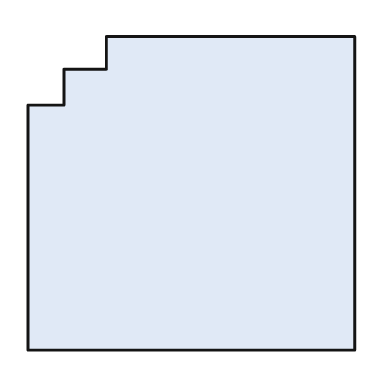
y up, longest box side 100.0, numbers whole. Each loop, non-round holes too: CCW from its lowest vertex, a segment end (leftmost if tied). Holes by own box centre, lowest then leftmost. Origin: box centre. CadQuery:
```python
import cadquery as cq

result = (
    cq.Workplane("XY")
    .moveTo(-50.0, -48.0)
    .lineTo(50.0, -48.0)
    .lineTo(50.0, 48.0)
    .lineTo(-26.0, 48.0)
    .lineTo(-26.0, 38.0)
    .lineTo(-39.0, 38.0)
    .lineTo(-39.0, 27.0)
    .lineTo(-50.0, 27.0)
    .close()
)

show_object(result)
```